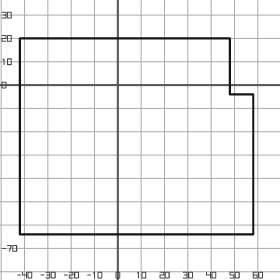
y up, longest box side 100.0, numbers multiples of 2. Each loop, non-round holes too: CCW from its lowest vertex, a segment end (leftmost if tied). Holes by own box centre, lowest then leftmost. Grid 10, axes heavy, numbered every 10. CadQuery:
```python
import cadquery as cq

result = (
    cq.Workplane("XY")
    .moveTo(-42.0, -64.0)
    .lineTo(58.0, -64.0)
    .lineTo(58.0, -4.0)
    .lineTo(48.0, -4.0)
    .lineTo(48.0, 20.0)
    .lineTo(-42.0, 20.0)
    .close()
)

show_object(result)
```